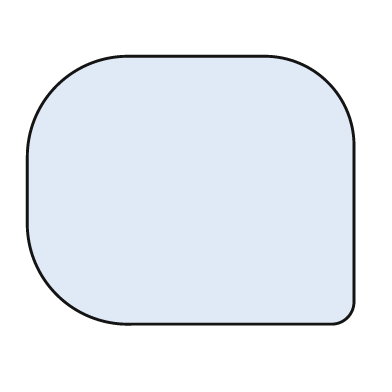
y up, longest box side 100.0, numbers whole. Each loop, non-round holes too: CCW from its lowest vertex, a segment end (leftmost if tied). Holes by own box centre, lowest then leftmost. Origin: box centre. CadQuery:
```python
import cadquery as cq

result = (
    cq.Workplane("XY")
    .moveTo(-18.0, -41.0)
    .lineTo(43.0, -41.0)
    .threePointArc((48.0, -39.0), (50.0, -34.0))
    .lineTo(50.0, 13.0)
    .threePointArc((42.0, 33.0), (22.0, 41.0))
    .lineTo(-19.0, 41.0)
    .threePointArc((-41.0, 32.0), (-50.0, 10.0))
    .lineTo(-50.0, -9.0)
    .threePointArc((-41.0, -32.0), (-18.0, -41.0))
    .close()
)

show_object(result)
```